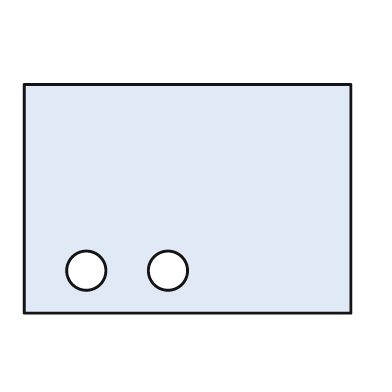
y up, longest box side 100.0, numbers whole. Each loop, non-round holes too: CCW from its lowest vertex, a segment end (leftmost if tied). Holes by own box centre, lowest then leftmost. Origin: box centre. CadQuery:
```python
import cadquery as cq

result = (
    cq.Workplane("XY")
    .moveTo(-50.0, -35.0)
    .lineTo(50.0, -35.0)
    .lineTo(50.0, 35.0)
    .lineTo(-50.0, 35.0)
    .close()
    .moveTo(-31.0, -22.0)
    .circle(6.0)
    .moveTo(-6.0, -22.0)
    .circle(6.0)
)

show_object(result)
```